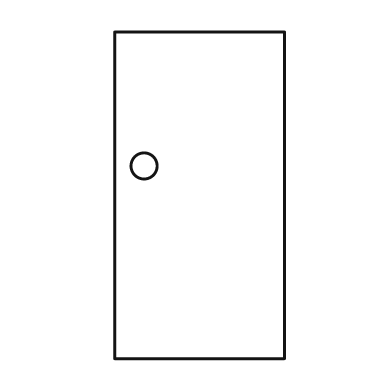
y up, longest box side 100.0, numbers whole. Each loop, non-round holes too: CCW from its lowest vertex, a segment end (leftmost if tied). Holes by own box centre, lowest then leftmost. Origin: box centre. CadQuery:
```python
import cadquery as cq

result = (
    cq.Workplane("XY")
    .moveTo(-26.0, -50.0)
    .lineTo(26.0, -50.0)
    .lineTo(26.0, 50.0)
    .lineTo(-26.0, 50.0)
    .close()
    .moveTo(-17.0, 9.0)
    .circle(4.0)
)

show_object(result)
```